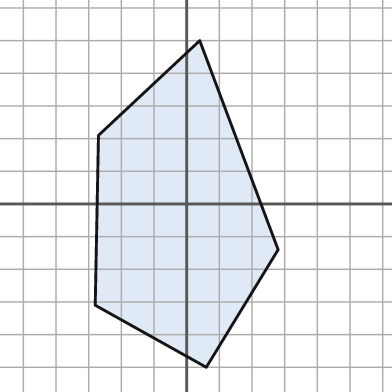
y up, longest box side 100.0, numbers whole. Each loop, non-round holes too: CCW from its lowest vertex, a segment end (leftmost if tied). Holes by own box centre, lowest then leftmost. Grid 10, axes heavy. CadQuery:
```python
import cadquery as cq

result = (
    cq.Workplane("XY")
    .moveTo(6.0, -50.0)
    .lineTo(28.0, -14.0)
    .lineTo(4.0, 50.0)
    .lineTo(-27.0, 21.0)
    .lineTo(-28.0, -31.0)
    .close()
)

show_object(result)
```